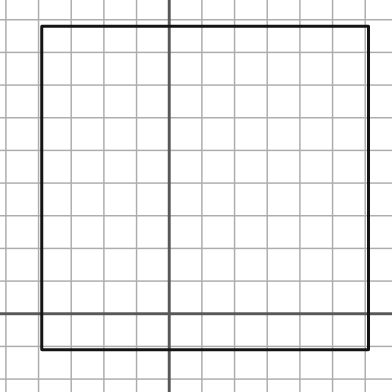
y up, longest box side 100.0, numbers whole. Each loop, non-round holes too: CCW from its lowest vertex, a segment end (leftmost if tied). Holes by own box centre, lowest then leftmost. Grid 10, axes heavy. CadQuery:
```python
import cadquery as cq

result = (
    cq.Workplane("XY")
    .moveTo(-39.0, -11.0)
    .lineTo(61.0, -11.0)
    .lineTo(61.0, 88.0)
    .lineTo(-39.0, 88.0)
    .close()
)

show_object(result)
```